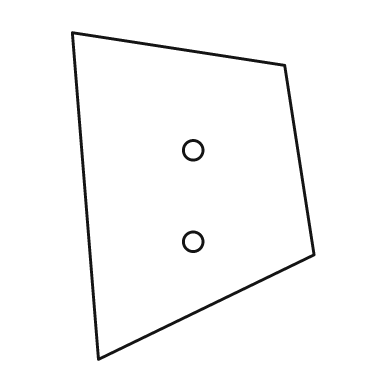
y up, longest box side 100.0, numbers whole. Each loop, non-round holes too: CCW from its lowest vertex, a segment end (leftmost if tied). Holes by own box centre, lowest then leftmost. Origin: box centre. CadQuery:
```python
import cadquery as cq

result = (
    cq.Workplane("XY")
    .moveTo(-29.0, -50.0)
    .lineTo(37.0, -18.0)
    .lineTo(28.0, 40.0)
    .lineTo(-37.0, 50.0)
    .close()
    .moveTo(0.0, -14.0)
    .circle(3.0)
    .moveTo(0.0, 14.0)
    .circle(3.0)
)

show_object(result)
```